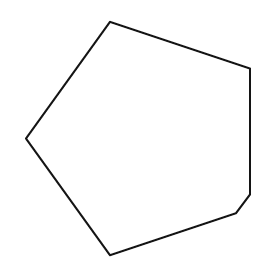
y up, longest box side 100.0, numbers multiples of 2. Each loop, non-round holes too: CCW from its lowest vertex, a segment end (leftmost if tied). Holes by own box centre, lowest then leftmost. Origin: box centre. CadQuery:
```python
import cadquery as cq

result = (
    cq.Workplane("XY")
    .moveTo(-12.0, -50.0)
    .lineTo(42.0, -32.0)
    .lineTo(48.0, -24.0)
    .lineTo(48.0, 30.0)
    .lineTo(-12.0, 50.0)
    .lineTo(-48.0, 0.0)
    .close()
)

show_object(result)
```